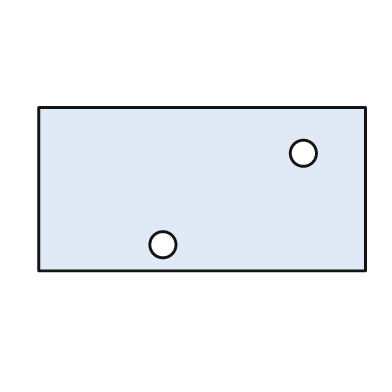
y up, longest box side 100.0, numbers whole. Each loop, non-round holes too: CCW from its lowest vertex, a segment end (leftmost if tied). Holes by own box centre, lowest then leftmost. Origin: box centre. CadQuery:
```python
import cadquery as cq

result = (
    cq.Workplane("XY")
    .moveTo(-50.0, -25.0)
    .lineTo(50.0, -25.0)
    .lineTo(50.0, 25.0)
    .lineTo(-50.0, 25.0)
    .close()
    .moveTo(-12.0, -17.0)
    .circle(4.0)
    .moveTo(31.0, 11.0)
    .circle(4.0)
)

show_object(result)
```